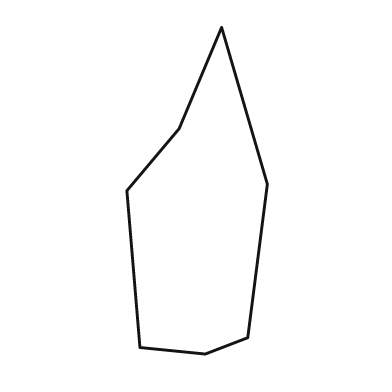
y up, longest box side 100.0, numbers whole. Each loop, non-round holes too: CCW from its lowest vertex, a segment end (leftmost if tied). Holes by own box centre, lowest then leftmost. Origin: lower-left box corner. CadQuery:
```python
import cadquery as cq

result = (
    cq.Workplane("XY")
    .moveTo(24.0, 0.0)
    .lineTo(37.0, 5.0)
    .lineTo(43.0, 52.0)
    .lineTo(29.0, 100.0)
    .lineTo(16.0, 69.0)
    .lineTo(0.0, 50.0)
    .lineTo(4.0, 2.0)
    .close()
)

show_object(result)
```